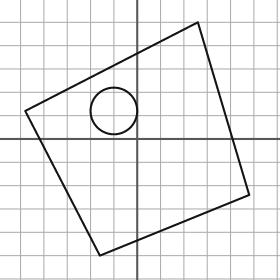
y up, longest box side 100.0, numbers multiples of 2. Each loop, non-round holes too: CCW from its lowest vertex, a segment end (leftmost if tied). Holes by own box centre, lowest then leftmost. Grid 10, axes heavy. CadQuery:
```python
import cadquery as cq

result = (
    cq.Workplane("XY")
    .moveTo(-16.0, -50.0)
    .lineTo(48.0, -24.0)
    .lineTo(26.0, 50.0)
    .lineTo(-48.0, 12.0)
    .close()
    .moveTo(-10.0, 12.0)
    .circle(10.0)
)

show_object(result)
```